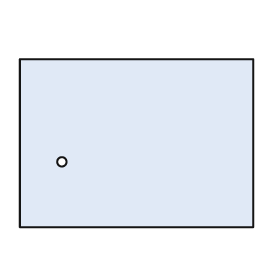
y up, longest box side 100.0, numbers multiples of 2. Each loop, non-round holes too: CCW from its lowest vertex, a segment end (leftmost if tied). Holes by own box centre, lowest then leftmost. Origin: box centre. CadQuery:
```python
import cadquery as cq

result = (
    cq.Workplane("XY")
    .moveTo(-50.0, -36.0)
    .lineTo(50.0, -36.0)
    .lineTo(50.0, 36.0)
    .lineTo(-50.0, 36.0)
    .close()
    .moveTo(-32.0, -8.0)
    .circle(2.0)
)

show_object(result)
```